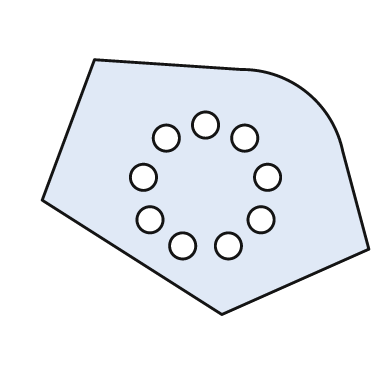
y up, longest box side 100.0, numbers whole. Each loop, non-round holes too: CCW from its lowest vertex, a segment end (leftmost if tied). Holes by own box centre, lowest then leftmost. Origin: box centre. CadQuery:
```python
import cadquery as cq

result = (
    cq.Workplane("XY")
    .moveTo(5.0, -39.0)
    .lineTo(50.0, -19.0)
    .lineTo(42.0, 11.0)
    .threePointArc((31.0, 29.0), (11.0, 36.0))
    .lineTo(-34.0, 39.0)
    .lineTo(-50.0, -4.0)
    .close()
    .moveTo(-7.0, -18.0)
    .circle(4.0)
    .moveTo(7.0, -18.0)
    .circle(4.0)
    .moveTo(-17.0, -10.0)
    .circle(4.0)
    .moveTo(17.0, -10.0)
    .circle(4.0)
    .moveTo(-19.0, 3.0)
    .circle(4.0)
    .moveTo(19.0, 3.0)
    .circle(4.0)
    .moveTo(-12.0, 15.0)
    .circle(4.0)
    .moveTo(12.0, 15.0)
    .circle(4.0)
    .moveTo(0.0, 19.0)
    .circle(4.0)
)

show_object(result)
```